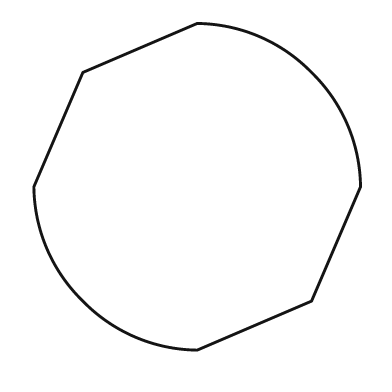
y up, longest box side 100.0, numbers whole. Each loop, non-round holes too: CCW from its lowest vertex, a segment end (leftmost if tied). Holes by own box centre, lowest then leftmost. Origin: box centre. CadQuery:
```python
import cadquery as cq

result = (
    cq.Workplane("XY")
    .moveTo(0.0, -50.0)
    .lineTo(35.0, -35.0)
    .lineTo(50.0, 0.0)
    .threePointArc((46.0, 19.0), (35.0, 35.0))
    .threePointArc((19.0, 46.0), (0.0, 50.0))
    .lineTo(-35.0, 35.0)
    .lineTo(-50.0, 0.0)
    .threePointArc((-46.0, -19.0), (-35.0, -35.0))
    .threePointArc((-19.0, -46.0), (0.0, -50.0))
    .close()
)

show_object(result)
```